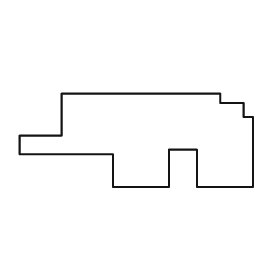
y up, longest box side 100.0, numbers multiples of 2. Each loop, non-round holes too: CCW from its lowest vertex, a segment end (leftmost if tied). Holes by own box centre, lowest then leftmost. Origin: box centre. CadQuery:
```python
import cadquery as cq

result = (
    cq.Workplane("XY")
    .moveTo(-10.0, -20.0)
    .lineTo(14.0, -20.0)
    .lineTo(14.0, -4.0)
    .lineTo(26.0, -4.0)
    .lineTo(26.0, -20.0)
    .lineTo(50.0, -20.0)
    .lineTo(50.0, 10.0)
    .lineTo(46.0, 10.0)
    .lineTo(46.0, 16.0)
    .lineTo(36.0, 16.0)
    .lineTo(36.0, 20.0)
    .lineTo(-32.0, 20.0)
    .lineTo(-32.0, 2.0)
    .lineTo(-50.0, 2.0)
    .lineTo(-50.0, -6.0)
    .lineTo(-10.0, -6.0)
    .close()
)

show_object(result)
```